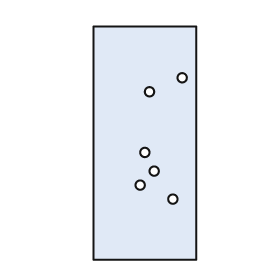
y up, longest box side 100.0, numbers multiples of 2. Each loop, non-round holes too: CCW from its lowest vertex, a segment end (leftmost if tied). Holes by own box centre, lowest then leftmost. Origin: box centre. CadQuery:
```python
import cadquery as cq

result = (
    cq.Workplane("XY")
    .moveTo(-22.0, -50.0)
    .lineTo(22.0, -50.0)
    .lineTo(22.0, 50.0)
    .lineTo(-22.0, 50.0)
    .close()
    .moveTo(12.0, -24.0)
    .circle(2.0)
    .moveTo(-2.0, -18.0)
    .circle(2.0)
    .moveTo(4.0, -12.0)
    .circle(2.0)
    .moveTo(0.0, -4.0)
    .circle(2.0)
    .moveTo(2.0, 22.0)
    .circle(2.0)
    .moveTo(16.0, 28.0)
    .circle(2.0)
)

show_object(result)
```